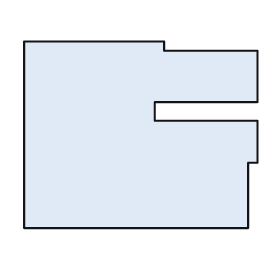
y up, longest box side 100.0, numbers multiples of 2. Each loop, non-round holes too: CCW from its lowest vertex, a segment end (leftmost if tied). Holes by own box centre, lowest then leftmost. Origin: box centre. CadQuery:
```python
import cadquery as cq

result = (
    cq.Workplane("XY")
    .moveTo(-50.0, -40.0)
    .lineTo(46.0, -40.0)
    .lineTo(46.0, -12.0)
    .lineTo(50.0, -12.0)
    .lineTo(50.0, 6.0)
    .lineTo(6.0, 6.0)
    .lineTo(6.0, 14.0)
    .lineTo(50.0, 14.0)
    .lineTo(50.0, 36.0)
    .lineTo(10.0, 36.0)
    .lineTo(10.0, 40.0)
    .lineTo(-50.0, 40.0)
    .close()
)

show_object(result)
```